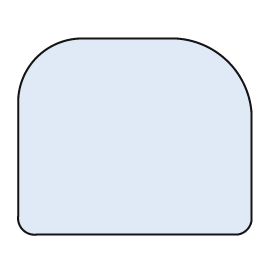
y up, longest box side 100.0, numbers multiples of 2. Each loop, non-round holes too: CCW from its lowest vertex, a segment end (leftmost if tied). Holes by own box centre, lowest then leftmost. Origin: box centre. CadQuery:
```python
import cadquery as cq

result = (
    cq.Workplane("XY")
    .moveTo(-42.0, -42.0)
    .lineTo(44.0, -42.0)
    .threePointArc((48.0, -40.0), (50.0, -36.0))
    .lineTo(50.0, 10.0)
    .threePointArc((40.0, 32.0), (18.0, 42.0))
    .lineTo(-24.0, 42.0)
    .threePointArc((-42.0, 34.0), (-50.0, 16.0))
    .lineTo(-50.0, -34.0)
    .threePointArc((-48.0, -40.0), (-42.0, -42.0))
    .close()
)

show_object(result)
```